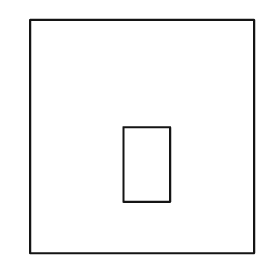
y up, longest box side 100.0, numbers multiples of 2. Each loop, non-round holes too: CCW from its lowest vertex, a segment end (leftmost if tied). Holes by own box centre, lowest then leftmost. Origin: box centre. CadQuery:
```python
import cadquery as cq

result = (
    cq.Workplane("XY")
    .moveTo(-48.0, -50.0)
    .lineTo(48.0, -50.0)
    .lineTo(48.0, 50.0)
    .lineTo(-48.0, 50.0)
    .close()
    .moveTo(-8.0, -28.0)
    .lineTo(12.0, -28.0)
    .lineTo(12.0, 4.0)
    .lineTo(-8.0, 4.0)
    .close()
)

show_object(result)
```